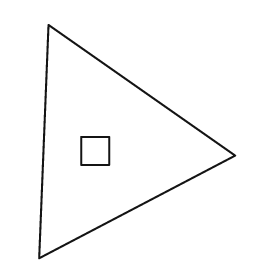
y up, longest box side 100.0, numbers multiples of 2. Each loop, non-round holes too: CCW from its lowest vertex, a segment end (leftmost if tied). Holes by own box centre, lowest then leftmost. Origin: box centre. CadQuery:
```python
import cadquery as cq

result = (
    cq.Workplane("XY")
    .moveTo(-42.0, -50.0)
    .lineTo(42.0, -6.0)
    .lineTo(-38.0, 50.0)
    .close()
    .moveTo(-24.0, -10.0)
    .lineTo(-12.0, -10.0)
    .lineTo(-12.0, 2.0)
    .lineTo(-24.0, 2.0)
    .close()
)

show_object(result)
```